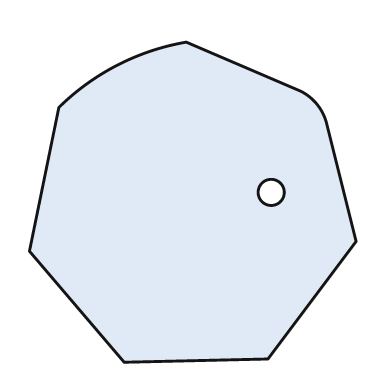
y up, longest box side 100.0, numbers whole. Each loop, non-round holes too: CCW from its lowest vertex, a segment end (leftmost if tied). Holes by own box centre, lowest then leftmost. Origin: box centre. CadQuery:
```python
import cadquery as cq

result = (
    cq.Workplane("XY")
    .moveTo(-21.0, -49.0)
    .lineTo(23.0, -48.0)
    .lineTo(50.0, -12.0)
    .lineTo(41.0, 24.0)
    .threePointArc((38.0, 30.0), (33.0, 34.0))
    .lineTo(-2.0, 49.0)
    .threePointArc((-23.0, 42.0), (-41.0, 29.0))
    .lineTo(-50.0, -15.0)
    .close()
    .moveTo(24.0, 3.0)
    .circle(4.0)
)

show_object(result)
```